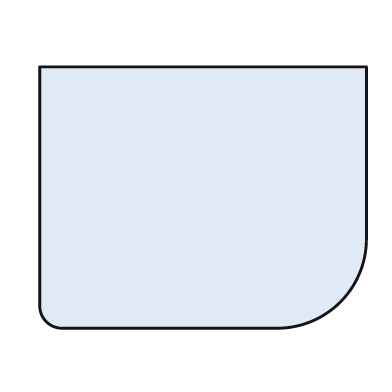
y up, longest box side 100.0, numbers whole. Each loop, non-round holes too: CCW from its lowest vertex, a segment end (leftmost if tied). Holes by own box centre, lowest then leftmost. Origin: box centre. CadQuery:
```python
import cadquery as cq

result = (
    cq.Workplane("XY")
    .moveTo(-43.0, -40.0)
    .lineTo(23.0, -40.0)
    .threePointArc((42.0, -32.0), (50.0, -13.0))
    .lineTo(50.0, 40.0)
    .lineTo(-50.0, 40.0)
    .lineTo(-50.0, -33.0)
    .threePointArc((-48.0, -38.0), (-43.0, -40.0))
    .close()
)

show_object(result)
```